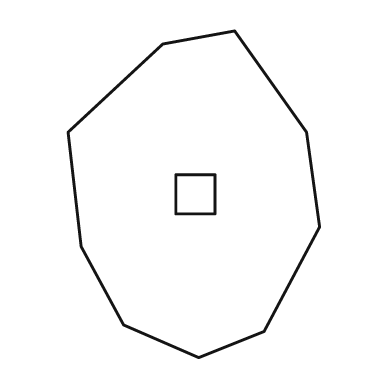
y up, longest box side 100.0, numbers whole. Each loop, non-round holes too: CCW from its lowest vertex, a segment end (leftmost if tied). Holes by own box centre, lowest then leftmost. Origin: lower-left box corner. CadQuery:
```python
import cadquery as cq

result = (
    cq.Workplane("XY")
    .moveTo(40.0, 0.0)
    .lineTo(60.0, 8.0)
    .lineTo(77.0, 40.0)
    .lineTo(73.0, 69.0)
    .lineTo(51.0, 100.0)
    .lineTo(29.0, 96.0)
    .lineTo(0.0, 69.0)
    .lineTo(4.0, 34.0)
    .lineTo(17.0, 10.0)
    .close()
    .moveTo(33.0, 44.0)
    .lineTo(45.0, 44.0)
    .lineTo(45.0, 56.0)
    .lineTo(33.0, 56.0)
    .close()
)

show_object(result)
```